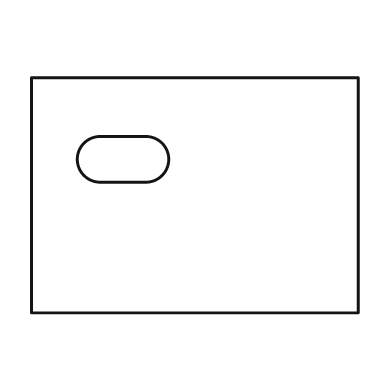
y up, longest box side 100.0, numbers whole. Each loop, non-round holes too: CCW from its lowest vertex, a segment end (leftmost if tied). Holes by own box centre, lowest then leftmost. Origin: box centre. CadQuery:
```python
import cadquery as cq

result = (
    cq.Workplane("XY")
    .moveTo(-50.0, -36.0)
    .lineTo(50.0, -36.0)
    .lineTo(50.0, 36.0)
    .lineTo(-50.0, 36.0)
    .close()
    .moveTo(-29.0, 4.0)
    .lineTo(-15.0, 4.0)
    .threePointArc((-8.0, 11.0), (-15.0, 18.0))
    .lineTo(-29.0, 18.0)
    .threePointArc((-36.0, 11.0), (-29.0, 4.0))
    .close()
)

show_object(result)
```